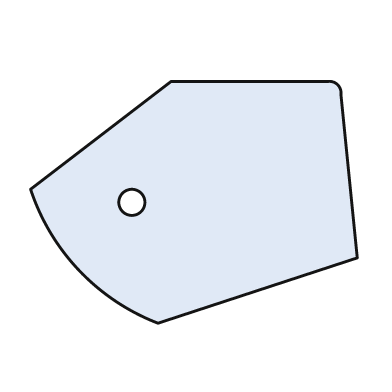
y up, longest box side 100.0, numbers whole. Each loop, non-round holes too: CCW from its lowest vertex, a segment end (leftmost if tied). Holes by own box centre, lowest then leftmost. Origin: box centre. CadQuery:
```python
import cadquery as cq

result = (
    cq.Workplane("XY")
    .moveTo(-11.0, -37.0)
    .lineTo(50.0, -17.0)
    .lineTo(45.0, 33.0)
    .threePointArc((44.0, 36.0), (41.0, 37.0))
    .lineTo(-7.0, 37.0)
    .lineTo(-50.0, 4.0)
    .threePointArc((-35.0, -21.0), (-11.0, -37.0))
    .close()
    .moveTo(-19.0, 0.0)
    .circle(4.0)
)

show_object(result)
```